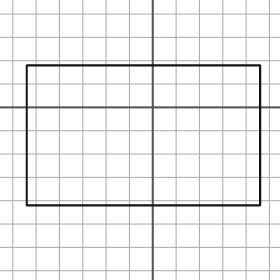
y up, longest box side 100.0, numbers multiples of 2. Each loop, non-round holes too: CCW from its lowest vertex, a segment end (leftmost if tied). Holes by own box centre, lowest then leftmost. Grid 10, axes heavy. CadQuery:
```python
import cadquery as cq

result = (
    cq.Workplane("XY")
    .moveTo(-54.0, -42.0)
    .lineTo(46.0, -42.0)
    .lineTo(46.0, 18.0)
    .lineTo(-54.0, 18.0)
    .close()
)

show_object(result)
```